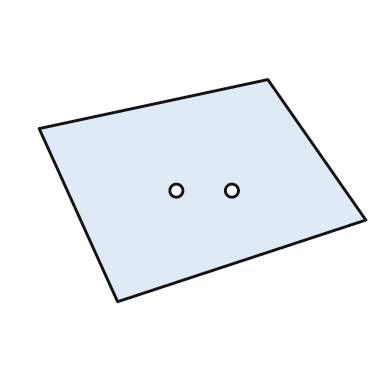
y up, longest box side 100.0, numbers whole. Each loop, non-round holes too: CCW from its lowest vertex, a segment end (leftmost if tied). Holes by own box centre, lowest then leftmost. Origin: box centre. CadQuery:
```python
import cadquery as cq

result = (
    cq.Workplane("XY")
    .moveTo(-26.0, -34.0)
    .lineTo(50.0, -9.0)
    .lineTo(20.0, 34.0)
    .lineTo(-50.0, 19.0)
    .close()
    .moveTo(-8.0, 0.0)
    .circle(2.0)
    .moveTo(9.0, 0.0)
    .circle(2.0)
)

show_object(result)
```